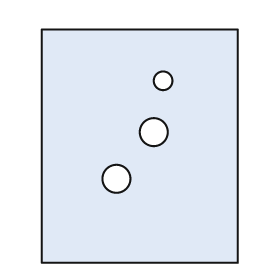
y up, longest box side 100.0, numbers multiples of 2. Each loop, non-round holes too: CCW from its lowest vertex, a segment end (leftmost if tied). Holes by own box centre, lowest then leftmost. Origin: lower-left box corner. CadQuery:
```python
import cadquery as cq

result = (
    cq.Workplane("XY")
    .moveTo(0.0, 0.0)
    .lineTo(84.0, 0.0)
    .lineTo(84.0, 100.0)
    .lineTo(0.0, 100.0)
    .close()
    .moveTo(32.0, 36.0)
    .circle(6.0)
    .moveTo(48.0, 56.0)
    .circle(6.0)
    .moveTo(52.0, 78.0)
    .circle(4.0)
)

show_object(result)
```